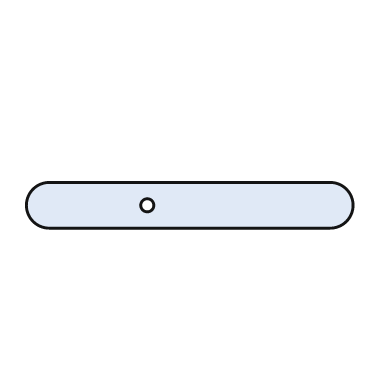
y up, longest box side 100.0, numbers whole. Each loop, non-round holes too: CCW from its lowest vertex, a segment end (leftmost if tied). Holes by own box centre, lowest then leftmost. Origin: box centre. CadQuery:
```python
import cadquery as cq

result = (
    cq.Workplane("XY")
    .moveTo(-43.0, -7.0)
    .lineTo(43.0, -7.0)
    .threePointArc((50.0, 0.0), (43.0, 7.0))
    .lineTo(-43.0, 7.0)
    .threePointArc((-50.0, 0.0), (-43.0, -7.0))
    .close()
    .moveTo(-13.0, 0.0)
    .circle(2.0)
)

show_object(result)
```